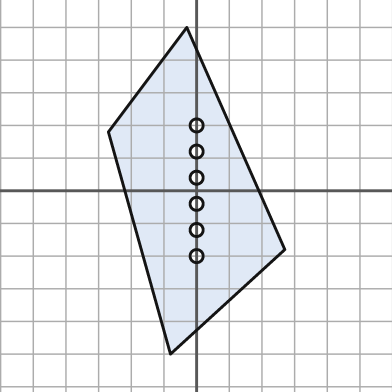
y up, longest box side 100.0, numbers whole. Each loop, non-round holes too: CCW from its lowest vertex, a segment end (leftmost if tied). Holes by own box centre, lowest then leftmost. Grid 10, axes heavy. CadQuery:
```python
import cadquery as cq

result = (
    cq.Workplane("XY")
    .moveTo(-8.0, -50.0)
    .lineTo(27.0, -18.0)
    .lineTo(-3.0, 50.0)
    .lineTo(-27.0, 18.0)
    .close()
    .moveTo(0.0, -20.0)
    .circle(2.0)
    .moveTo(0.0, -12.0)
    .circle(2.0)
    .moveTo(0.0, -4.0)
    .circle(2.0)
    .moveTo(0.0, 4.0)
    .circle(2.0)
    .moveTo(0.0, 12.0)
    .circle(2.0)
    .moveTo(0.0, 20.0)
    .circle(2.0)
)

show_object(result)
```